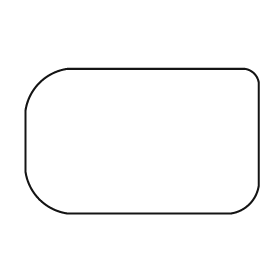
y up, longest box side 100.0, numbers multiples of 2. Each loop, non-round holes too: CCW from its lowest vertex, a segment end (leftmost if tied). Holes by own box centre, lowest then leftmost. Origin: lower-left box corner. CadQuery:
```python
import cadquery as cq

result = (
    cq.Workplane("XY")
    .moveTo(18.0, 0.0)
    .lineTo(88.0, 0.0)
    .threePointArc((96.0, 4.0), (100.0, 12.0))
    .lineTo(100.0, 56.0)
    .threePointArc((98.0, 60.0), (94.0, 62.0))
    .lineTo(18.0, 62.0)
    .threePointArc((6.0, 56.0), (0.0, 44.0))
    .lineTo(0.0, 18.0)
    .threePointArc((6.0, 6.0), (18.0, 0.0))
    .close()
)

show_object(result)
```